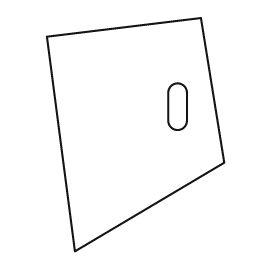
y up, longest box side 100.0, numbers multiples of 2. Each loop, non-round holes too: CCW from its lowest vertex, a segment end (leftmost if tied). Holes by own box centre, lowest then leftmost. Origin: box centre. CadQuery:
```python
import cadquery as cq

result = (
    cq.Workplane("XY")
    .moveTo(-26.0, -50.0)
    .lineTo(38.0, -12.0)
    .lineTo(28.0, 50.0)
    .lineTo(-38.0, 42.0)
    .close()
    .moveTo(14.0, 6.0)
    .threePointArc((18.0, 2.0), (22.0, 6.0))
    .lineTo(22.0, 18.0)
    .threePointArc((18.0, 22.0), (14.0, 18.0))
    .close()
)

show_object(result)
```